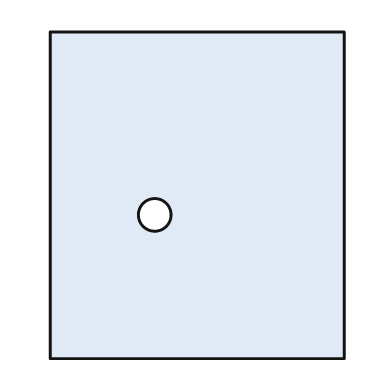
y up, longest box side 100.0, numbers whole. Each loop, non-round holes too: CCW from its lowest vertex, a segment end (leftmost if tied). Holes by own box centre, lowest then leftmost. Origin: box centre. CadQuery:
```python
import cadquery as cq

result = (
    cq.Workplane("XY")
    .moveTo(-45.0, -50.0)
    .lineTo(45.0, -50.0)
    .lineTo(45.0, 50.0)
    .lineTo(-45.0, 50.0)
    .close()
    .moveTo(-13.0, -6.0)
    .circle(5.0)
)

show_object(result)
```